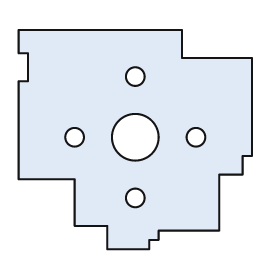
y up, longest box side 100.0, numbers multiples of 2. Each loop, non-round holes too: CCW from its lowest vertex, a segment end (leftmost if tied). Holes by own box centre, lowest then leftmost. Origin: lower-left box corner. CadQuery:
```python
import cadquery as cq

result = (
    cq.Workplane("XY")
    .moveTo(38.0, 0.0)
    .lineTo(56.0, 0.0)
    .lineTo(56.0, 4.0)
    .lineTo(60.0, 4.0)
    .lineTo(60.0, 8.0)
    .lineTo(86.0, 8.0)
    .lineTo(86.0, 32.0)
    .lineTo(96.0, 32.0)
    .lineTo(96.0, 40.0)
    .lineTo(100.0, 40.0)
    .lineTo(100.0, 82.0)
    .lineTo(70.0, 82.0)
    .lineTo(70.0, 94.0)
    .lineTo(0.0, 94.0)
    .lineTo(0.0, 84.0)
    .lineTo(4.0, 84.0)
    .lineTo(4.0, 72.0)
    .lineTo(0.0, 72.0)
    .lineTo(0.0, 30.0)
    .lineTo(24.0, 30.0)
    .lineTo(24.0, 10.0)
    .lineTo(38.0, 10.0)
    .close()
    .moveTo(50.0, 22.0)
    .circle(4.0)
    .moveTo(24.0, 48.0)
    .circle(4.0)
    .moveTo(50.0, 48.0)
    .circle(10.0)
    .moveTo(76.0, 48.0)
    .circle(4.0)
    .moveTo(50.0, 74.0)
    .circle(4.0)
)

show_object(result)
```